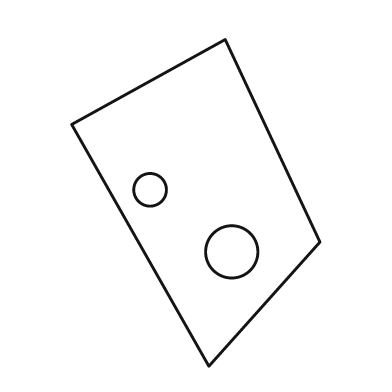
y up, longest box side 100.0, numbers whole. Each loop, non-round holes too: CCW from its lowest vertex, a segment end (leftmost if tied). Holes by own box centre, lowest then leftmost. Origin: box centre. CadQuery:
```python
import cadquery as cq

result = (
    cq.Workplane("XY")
    .moveTo(4.0, -50.0)
    .lineTo(38.0, -12.0)
    .lineTo(9.0, 50.0)
    .lineTo(-38.0, 24.0)
    .close()
    .moveTo(11.0, -15.0)
    .circle(8.0)
    .moveTo(-14.0, 4.0)
    .circle(5.0)
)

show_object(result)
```